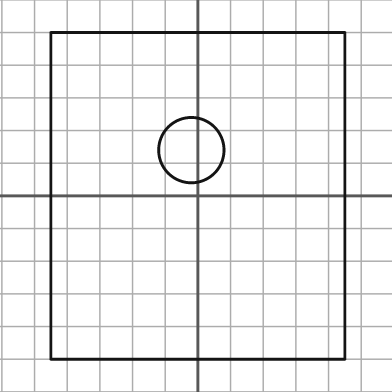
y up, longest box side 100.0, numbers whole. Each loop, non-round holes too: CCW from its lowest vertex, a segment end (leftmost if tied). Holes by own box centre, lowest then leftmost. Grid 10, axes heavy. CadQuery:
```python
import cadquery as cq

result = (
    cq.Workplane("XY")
    .moveTo(-45.0, -50.0)
    .lineTo(45.0, -50.0)
    .lineTo(45.0, 50.0)
    .lineTo(-45.0, 50.0)
    .close()
    .moveTo(-2.0, 14.0)
    .circle(10.0)
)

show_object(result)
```